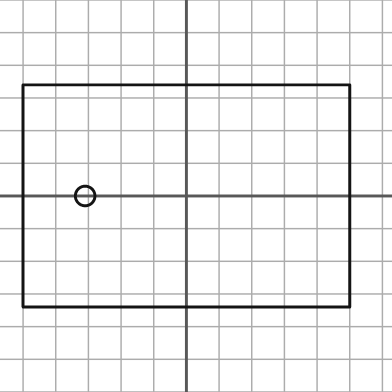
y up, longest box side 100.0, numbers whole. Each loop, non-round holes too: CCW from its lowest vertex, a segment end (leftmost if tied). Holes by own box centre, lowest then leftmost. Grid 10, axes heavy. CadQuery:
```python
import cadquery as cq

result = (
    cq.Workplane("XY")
    .moveTo(-50.0, -34.0)
    .lineTo(50.0, -34.0)
    .lineTo(50.0, 34.0)
    .lineTo(-50.0, 34.0)
    .close()
    .moveTo(-31.0, 0.0)
    .circle(3.0)
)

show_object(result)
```